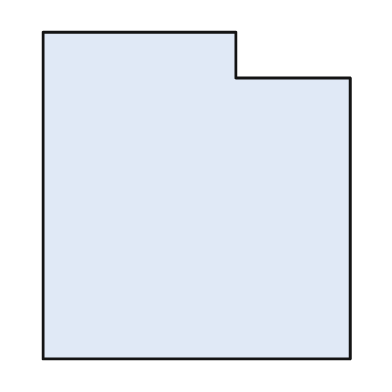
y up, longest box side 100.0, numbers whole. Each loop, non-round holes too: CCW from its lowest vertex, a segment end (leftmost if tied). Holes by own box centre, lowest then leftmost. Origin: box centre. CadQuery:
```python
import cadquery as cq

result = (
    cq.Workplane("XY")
    .moveTo(-47.0, -50.0)
    .lineTo(47.0, -50.0)
    .lineTo(47.0, 36.0)
    .lineTo(12.0, 36.0)
    .lineTo(12.0, 50.0)
    .lineTo(-47.0, 50.0)
    .close()
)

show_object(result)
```